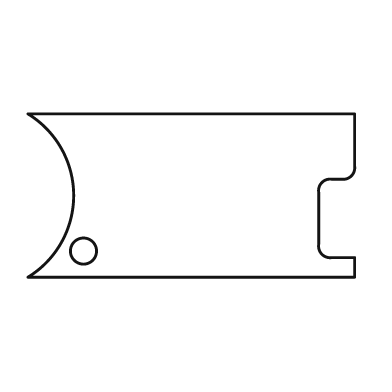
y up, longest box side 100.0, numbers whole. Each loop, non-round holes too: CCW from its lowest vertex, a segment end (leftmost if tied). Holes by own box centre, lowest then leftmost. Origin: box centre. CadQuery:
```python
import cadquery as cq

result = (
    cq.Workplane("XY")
    .moveTo(-50.0, -25.0)
    .lineTo(50.0, -25.0)
    .lineTo(50.0, -19.0)
    .lineTo(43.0, -19.0)
    .threePointArc((40.0, -18.0), (39.0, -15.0))
    .lineTo(39.0, 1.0)
    .threePointArc((40.0, 4.0), (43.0, 5.0))
    .lineTo(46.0, 5.0)
    .threePointArc((49.0, 6.0), (50.0, 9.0))
    .lineTo(50.0, 25.0)
    .lineTo(-50.0, 25.0)
    .threePointArc((-36.0, 0.0), (-50.0, -25.0))
    .close()
    .moveTo(-33.0, -17.0)
    .circle(4.0)
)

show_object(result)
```